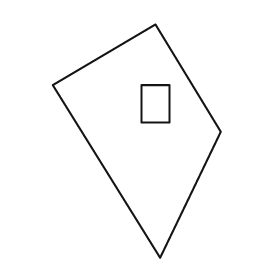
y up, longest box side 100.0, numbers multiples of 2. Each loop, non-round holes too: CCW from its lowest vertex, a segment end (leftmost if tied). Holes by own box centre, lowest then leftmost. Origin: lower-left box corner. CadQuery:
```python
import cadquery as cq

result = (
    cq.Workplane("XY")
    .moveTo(46.0, 0.0)
    .lineTo(72.0, 54.0)
    .lineTo(44.0, 100.0)
    .lineTo(0.0, 74.0)
    .close()
    .moveTo(38.0, 58.0)
    .lineTo(50.0, 58.0)
    .lineTo(50.0, 74.0)
    .lineTo(38.0, 74.0)
    .close()
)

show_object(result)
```